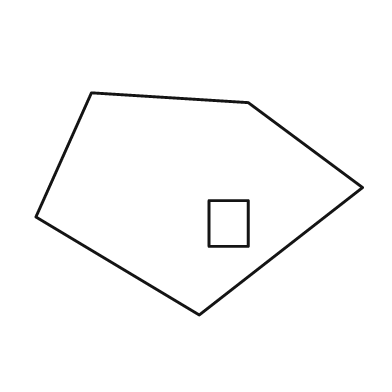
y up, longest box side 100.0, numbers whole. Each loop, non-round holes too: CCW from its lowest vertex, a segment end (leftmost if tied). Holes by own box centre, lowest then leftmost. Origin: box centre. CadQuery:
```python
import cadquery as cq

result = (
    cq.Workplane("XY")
    .moveTo(0.0, -34.0)
    .lineTo(50.0, 5.0)
    .lineTo(15.0, 31.0)
    .lineTo(-33.0, 34.0)
    .lineTo(-50.0, -4.0)
    .close()
    .moveTo(3.0, -13.0)
    .lineTo(15.0, -13.0)
    .lineTo(15.0, 1.0)
    .lineTo(3.0, 1.0)
    .close()
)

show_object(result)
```